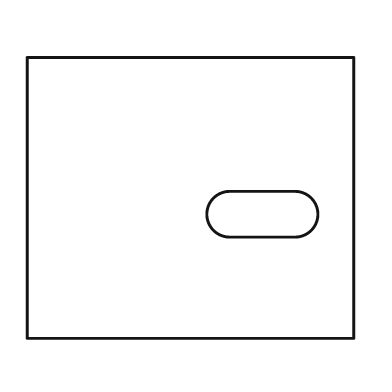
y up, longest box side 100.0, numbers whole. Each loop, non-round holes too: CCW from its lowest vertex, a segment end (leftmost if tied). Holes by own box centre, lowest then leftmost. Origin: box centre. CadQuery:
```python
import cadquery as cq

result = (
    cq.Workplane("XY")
    .moveTo(-50.0, -43.0)
    .lineTo(50.0, -43.0)
    .lineTo(50.0, 43.0)
    .lineTo(-50.0, 43.0)
    .close()
    .moveTo(12.0, -12.0)
    .lineTo(32.0, -12.0)
    .threePointArc((39.0, -5.0), (32.0, 2.0))
    .lineTo(12.0, 2.0)
    .threePointArc((5.0, -5.0), (12.0, -12.0))
    .close()
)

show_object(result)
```